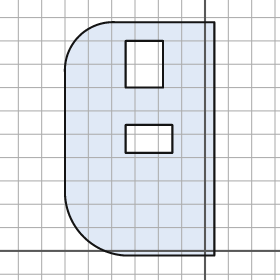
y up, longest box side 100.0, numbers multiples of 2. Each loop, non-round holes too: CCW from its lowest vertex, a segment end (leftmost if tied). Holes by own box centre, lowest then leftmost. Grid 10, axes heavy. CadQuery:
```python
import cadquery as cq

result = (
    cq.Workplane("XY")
    .moveTo(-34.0, -2.0)
    .lineTo(4.0, -2.0)
    .lineTo(4.0, 98.0)
    .lineTo(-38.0, 98.0)
    .threePointArc((-54.0, 92.0), (-60.0, 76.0))
    .lineTo(-60.0, 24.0)
    .threePointArc((-52.0, 6.0), (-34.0, -2.0))
    .close()
    .moveTo(-34.0, 42.0)
    .lineTo(-14.0, 42.0)
    .lineTo(-14.0, 54.0)
    .lineTo(-34.0, 54.0)
    .close()
    .moveTo(-34.0, 70.0)
    .lineTo(-18.0, 70.0)
    .lineTo(-18.0, 90.0)
    .lineTo(-34.0, 90.0)
    .close()
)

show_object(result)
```